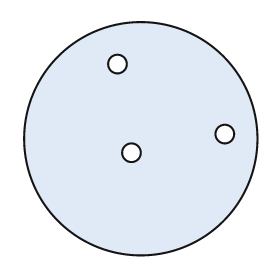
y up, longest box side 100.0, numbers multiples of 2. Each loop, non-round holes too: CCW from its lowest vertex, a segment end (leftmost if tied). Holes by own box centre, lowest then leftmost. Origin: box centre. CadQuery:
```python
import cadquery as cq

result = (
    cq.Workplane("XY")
    .moveTo(0.0, 0.0)
    .circle(50.0)
    .moveTo(-4.0, -6.0)
    .circle(4.0)
    .moveTo(36.0, 2.0)
    .circle(4.0)
    .moveTo(-10.0, 32.0)
    .circle(4.0)
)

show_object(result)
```